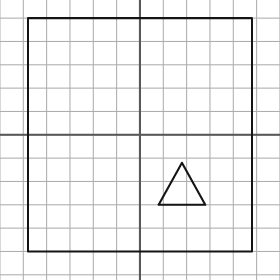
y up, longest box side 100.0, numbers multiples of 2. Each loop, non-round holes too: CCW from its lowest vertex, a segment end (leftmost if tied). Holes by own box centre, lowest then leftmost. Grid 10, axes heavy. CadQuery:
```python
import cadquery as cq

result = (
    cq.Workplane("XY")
    .moveTo(-48.0, -50.0)
    .lineTo(48.0, -50.0)
    .lineTo(48.0, 50.0)
    .lineTo(-48.0, 50.0)
    .close()
    .moveTo(8.0, -30.0)
    .lineTo(28.0, -30.0)
    .lineTo(18.0, -12.0)
    .close()
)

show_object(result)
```